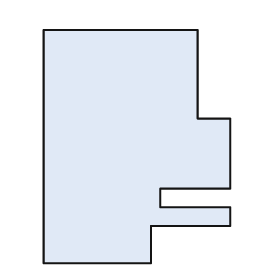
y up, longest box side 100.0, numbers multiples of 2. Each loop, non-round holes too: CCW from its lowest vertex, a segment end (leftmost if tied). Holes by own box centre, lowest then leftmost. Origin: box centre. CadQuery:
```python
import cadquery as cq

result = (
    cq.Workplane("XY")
    .moveTo(-40.0, -50.0)
    .lineTo(6.0, -50.0)
    .lineTo(6.0, -34.0)
    .lineTo(40.0, -34.0)
    .lineTo(40.0, -26.0)
    .lineTo(10.0, -26.0)
    .lineTo(10.0, -18.0)
    .lineTo(40.0, -18.0)
    .lineTo(40.0, 12.0)
    .lineTo(26.0, 12.0)
    .lineTo(26.0, 50.0)
    .lineTo(-40.0, 50.0)
    .close()
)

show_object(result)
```